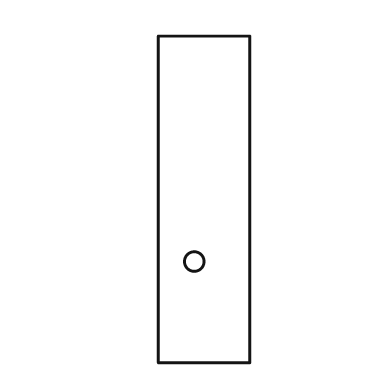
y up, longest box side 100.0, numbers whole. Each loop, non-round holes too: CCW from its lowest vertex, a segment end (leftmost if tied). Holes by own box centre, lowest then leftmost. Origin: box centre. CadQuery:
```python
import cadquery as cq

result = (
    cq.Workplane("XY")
    .moveTo(-14.0, -50.0)
    .lineTo(14.0, -50.0)
    .lineTo(14.0, 50.0)
    .lineTo(-14.0, 50.0)
    .close()
    .moveTo(-3.0, -19.0)
    .circle(3.0)
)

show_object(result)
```